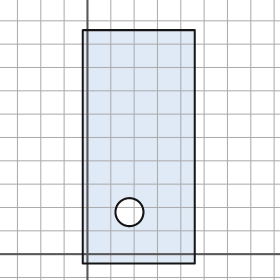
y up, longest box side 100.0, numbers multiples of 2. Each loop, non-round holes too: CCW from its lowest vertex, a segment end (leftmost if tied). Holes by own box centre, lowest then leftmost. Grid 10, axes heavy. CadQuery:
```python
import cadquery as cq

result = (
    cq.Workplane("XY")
    .moveTo(-2.0, -4.0)
    .lineTo(46.0, -4.0)
    .lineTo(46.0, 96.0)
    .lineTo(-2.0, 96.0)
    .close()
    .moveTo(18.0, 18.0)
    .circle(6.0)
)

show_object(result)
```